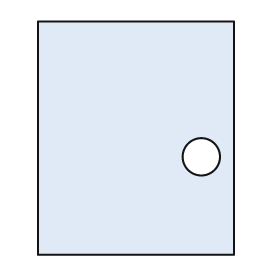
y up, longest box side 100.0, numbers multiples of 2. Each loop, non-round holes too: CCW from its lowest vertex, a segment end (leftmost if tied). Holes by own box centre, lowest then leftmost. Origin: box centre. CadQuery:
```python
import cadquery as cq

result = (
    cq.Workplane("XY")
    .moveTo(-42.0, -50.0)
    .lineTo(42.0, -50.0)
    .lineTo(42.0, 50.0)
    .lineTo(-42.0, 50.0)
    .close()
    .moveTo(28.0, -8.0)
    .circle(8.0)
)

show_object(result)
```